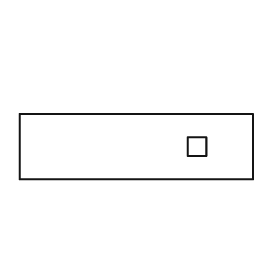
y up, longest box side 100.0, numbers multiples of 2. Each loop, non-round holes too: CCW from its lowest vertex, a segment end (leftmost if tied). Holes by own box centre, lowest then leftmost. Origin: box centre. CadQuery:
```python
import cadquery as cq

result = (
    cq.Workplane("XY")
    .moveTo(-50.0, -14.0)
    .lineTo(50.0, -14.0)
    .lineTo(50.0, 14.0)
    .lineTo(-50.0, 14.0)
    .close()
    .moveTo(22.0, -4.0)
    .lineTo(30.0, -4.0)
    .lineTo(30.0, 4.0)
    .lineTo(22.0, 4.0)
    .close()
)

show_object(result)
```